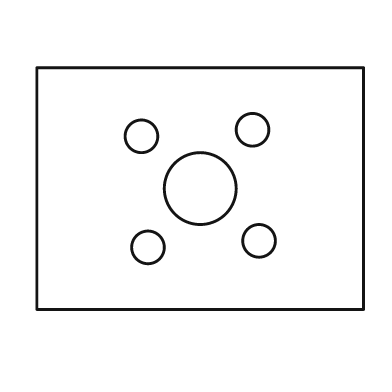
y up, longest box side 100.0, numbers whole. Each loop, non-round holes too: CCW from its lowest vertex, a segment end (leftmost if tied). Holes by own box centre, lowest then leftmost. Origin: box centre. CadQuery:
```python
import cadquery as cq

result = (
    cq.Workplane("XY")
    .moveTo(-50.0, -37.0)
    .lineTo(50.0, -37.0)
    .lineTo(50.0, 37.0)
    .lineTo(-50.0, 37.0)
    .close()
    .moveTo(-16.0, -18.0)
    .circle(5.0)
    .moveTo(18.0, -16.0)
    .circle(5.0)
    .moveTo(0.0, 0.0)
    .circle(11.0)
    .moveTo(-18.0, 16.0)
    .circle(5.0)
    .moveTo(16.0, 18.0)
    .circle(5.0)
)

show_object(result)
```